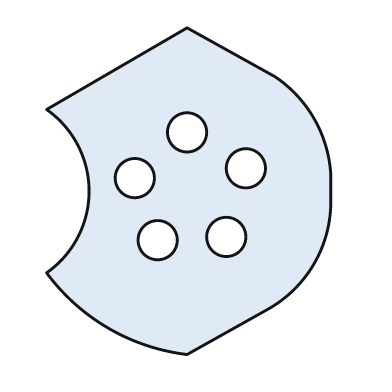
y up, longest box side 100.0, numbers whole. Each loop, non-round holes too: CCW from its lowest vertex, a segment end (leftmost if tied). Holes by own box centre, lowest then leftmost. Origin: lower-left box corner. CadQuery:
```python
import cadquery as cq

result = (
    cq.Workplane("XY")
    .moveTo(43.0, 0.0)
    .lineTo(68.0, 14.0)
    .threePointArc((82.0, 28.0), (87.0, 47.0))
    .lineTo(87.0, 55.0)
    .threePointArc((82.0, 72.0), (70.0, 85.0))
    .lineTo(43.0, 100.0)
    .lineTo(0.0, 75.0)
    .threePointArc((13.0, 50.0), (0.0, 25.0))
    .threePointArc((19.0, 8.0), (43.0, 0.0))
    .close()
    .moveTo(34.0, 35.0)
    .circle(6.0)
    .moveTo(55.0, 36.0)
    .circle(6.0)
    .moveTo(27.0, 54.0)
    .circle(6.0)
    .moveTo(61.0, 57.0)
    .circle(6.0)
    .moveTo(43.0, 68.0)
    .circle(6.0)
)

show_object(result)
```